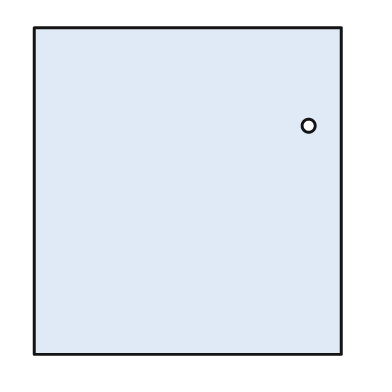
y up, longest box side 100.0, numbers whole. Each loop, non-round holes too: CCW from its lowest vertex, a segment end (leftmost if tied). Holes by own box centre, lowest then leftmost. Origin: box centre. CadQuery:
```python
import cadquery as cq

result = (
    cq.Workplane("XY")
    .moveTo(-47.0, -50.0)
    .lineTo(47.0, -50.0)
    .lineTo(47.0, 50.0)
    .lineTo(-47.0, 50.0)
    .close()
    .moveTo(37.0, 20.0)
    .circle(2.0)
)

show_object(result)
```